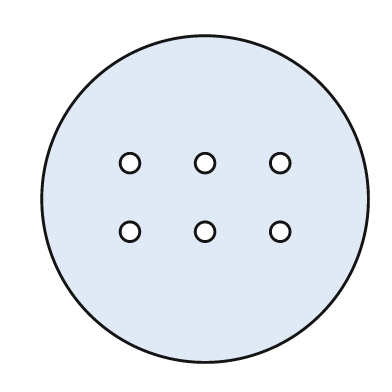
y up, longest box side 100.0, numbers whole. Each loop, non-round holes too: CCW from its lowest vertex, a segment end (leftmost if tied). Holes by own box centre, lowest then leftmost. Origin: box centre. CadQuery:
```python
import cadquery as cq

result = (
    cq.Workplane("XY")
    .moveTo(0.0, 0.0)
    .circle(50.0)
    .moveTo(-23.0, -10.0)
    .circle(3.0)
    .moveTo(0.0, -10.0)
    .circle(3.0)
    .moveTo(23.0, -10.0)
    .circle(3.0)
    .moveTo(-23.0, 11.0)
    .circle(3.0)
    .moveTo(0.0, 11.0)
    .circle(3.0)
    .moveTo(23.0, 11.0)
    .circle(3.0)
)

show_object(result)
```